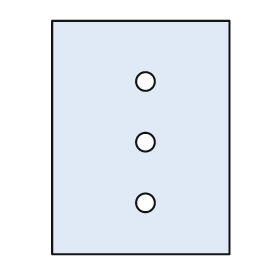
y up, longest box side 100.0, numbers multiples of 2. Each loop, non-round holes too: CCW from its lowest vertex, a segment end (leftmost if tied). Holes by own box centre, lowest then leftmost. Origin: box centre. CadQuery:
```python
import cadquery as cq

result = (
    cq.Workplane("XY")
    .moveTo(-38.0, -50.0)
    .lineTo(38.0, -50.0)
    .lineTo(38.0, 50.0)
    .lineTo(-38.0, 50.0)
    .close()
    .moveTo(2.0, -28.0)
    .circle(4.0)
    .moveTo(2.0, -2.0)
    .circle(4.0)
    .moveTo(2.0, 24.0)
    .circle(4.0)
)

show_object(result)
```